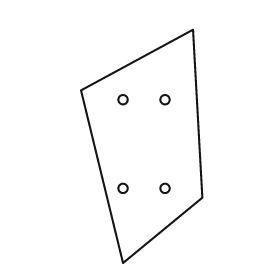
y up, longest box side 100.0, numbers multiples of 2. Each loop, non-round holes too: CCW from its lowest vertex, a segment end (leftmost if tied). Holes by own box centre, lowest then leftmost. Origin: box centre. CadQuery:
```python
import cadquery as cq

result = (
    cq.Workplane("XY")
    .moveTo(-8.0, -50.0)
    .lineTo(26.0, -22.0)
    .lineTo(22.0, 50.0)
    .lineTo(-26.0, 24.0)
    .close()
    .moveTo(-8.0, -18.0)
    .circle(2.0)
    .moveTo(10.0, -18.0)
    .circle(2.0)
    .moveTo(-8.0, 20.0)
    .circle(2.0)
    .moveTo(10.0, 20.0)
    .circle(2.0)
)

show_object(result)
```